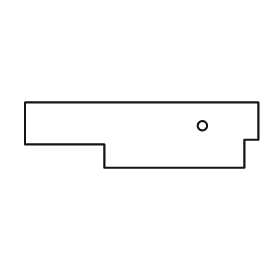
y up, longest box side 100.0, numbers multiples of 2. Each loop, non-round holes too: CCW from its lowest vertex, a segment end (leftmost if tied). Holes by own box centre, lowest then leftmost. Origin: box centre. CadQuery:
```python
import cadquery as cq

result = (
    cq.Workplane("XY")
    .moveTo(-16.0, -14.0)
    .lineTo(44.0, -14.0)
    .lineTo(44.0, -2.0)
    .lineTo(50.0, -2.0)
    .lineTo(50.0, 14.0)
    .lineTo(-50.0, 14.0)
    .lineTo(-50.0, -4.0)
    .lineTo(-16.0, -4.0)
    .close()
    .moveTo(26.0, 4.0)
    .circle(2.0)
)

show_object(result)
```